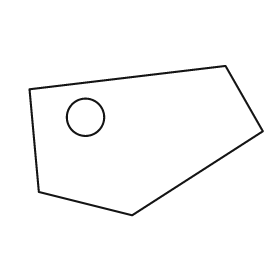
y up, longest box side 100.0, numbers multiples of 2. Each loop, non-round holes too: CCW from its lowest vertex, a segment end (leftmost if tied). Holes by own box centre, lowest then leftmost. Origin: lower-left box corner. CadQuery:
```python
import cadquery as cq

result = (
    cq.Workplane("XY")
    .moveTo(44.0, 0.0)
    .lineTo(100.0, 36.0)
    .lineTo(84.0, 64.0)
    .lineTo(0.0, 54.0)
    .lineTo(4.0, 10.0)
    .close()
    .moveTo(24.0, 42.0)
    .circle(8.0)
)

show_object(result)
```